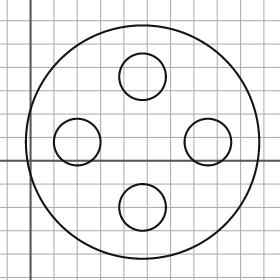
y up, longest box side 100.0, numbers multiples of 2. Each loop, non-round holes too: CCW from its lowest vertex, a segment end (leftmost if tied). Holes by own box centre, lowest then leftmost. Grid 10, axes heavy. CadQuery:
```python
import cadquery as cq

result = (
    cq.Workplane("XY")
    .moveTo(48.0, 8.0)
    .circle(50.0)
    .moveTo(48.0, -20.0)
    .circle(10.0)
    .moveTo(20.0, 8.0)
    .circle(10.0)
    .moveTo(76.0, 8.0)
    .circle(10.0)
    .moveTo(48.0, 36.0)
    .circle(10.0)
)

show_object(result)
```